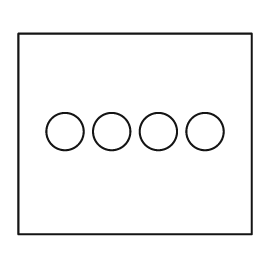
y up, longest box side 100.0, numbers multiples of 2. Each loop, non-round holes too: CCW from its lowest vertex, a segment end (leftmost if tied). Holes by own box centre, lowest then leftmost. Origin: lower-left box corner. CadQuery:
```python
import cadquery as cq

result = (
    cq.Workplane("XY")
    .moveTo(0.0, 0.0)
    .lineTo(100.0, 0.0)
    .lineTo(100.0, 86.0)
    .lineTo(0.0, 86.0)
    .close()
    .moveTo(20.0, 44.0)
    .circle(8.0)
    .moveTo(40.0, 44.0)
    .circle(8.0)
    .moveTo(60.0, 44.0)
    .circle(8.0)
    .moveTo(80.0, 44.0)
    .circle(8.0)
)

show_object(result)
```